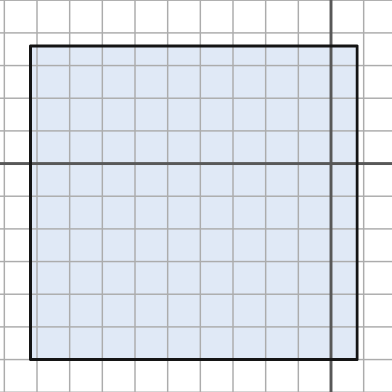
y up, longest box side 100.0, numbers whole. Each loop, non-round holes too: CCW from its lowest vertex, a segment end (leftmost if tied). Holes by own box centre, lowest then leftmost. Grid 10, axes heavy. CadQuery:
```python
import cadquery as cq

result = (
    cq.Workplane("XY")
    .moveTo(-92.0, -60.0)
    .lineTo(8.0, -60.0)
    .lineTo(8.0, 36.0)
    .lineTo(-92.0, 36.0)
    .close()
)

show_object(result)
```